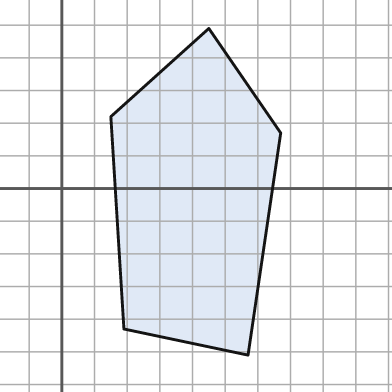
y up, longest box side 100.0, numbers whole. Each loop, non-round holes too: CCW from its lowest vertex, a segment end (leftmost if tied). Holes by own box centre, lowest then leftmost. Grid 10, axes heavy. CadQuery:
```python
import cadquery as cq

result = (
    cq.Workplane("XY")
    .moveTo(57.0, -51.0)
    .lineTo(67.0, 17.0)
    .lineTo(45.0, 49.0)
    .lineTo(15.0, 22.0)
    .lineTo(19.0, -43.0)
    .close()
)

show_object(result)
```